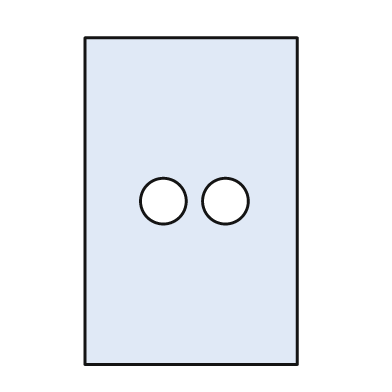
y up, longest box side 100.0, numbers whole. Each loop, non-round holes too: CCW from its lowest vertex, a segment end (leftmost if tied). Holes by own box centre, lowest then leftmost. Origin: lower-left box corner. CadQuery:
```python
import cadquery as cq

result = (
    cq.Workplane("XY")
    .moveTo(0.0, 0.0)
    .lineTo(65.0, 0.0)
    .lineTo(65.0, 100.0)
    .lineTo(0.0, 100.0)
    .close()
    .moveTo(24.0, 50.0)
    .circle(7.0)
    .moveTo(43.0, 50.0)
    .circle(7.0)
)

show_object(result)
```